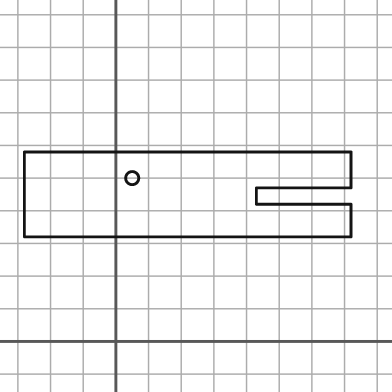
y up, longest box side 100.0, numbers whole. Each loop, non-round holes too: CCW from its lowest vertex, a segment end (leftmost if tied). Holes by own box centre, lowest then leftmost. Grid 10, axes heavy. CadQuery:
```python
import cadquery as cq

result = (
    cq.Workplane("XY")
    .moveTo(-28.0, 32.0)
    .lineTo(72.0, 32.0)
    .lineTo(72.0, 42.0)
    .lineTo(43.0, 42.0)
    .lineTo(43.0, 47.0)
    .lineTo(72.0, 47.0)
    .lineTo(72.0, 58.0)
    .lineTo(-28.0, 58.0)
    .close()
    .moveTo(5.0, 50.0)
    .circle(2.0)
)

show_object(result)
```